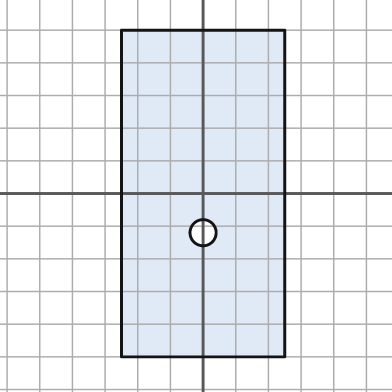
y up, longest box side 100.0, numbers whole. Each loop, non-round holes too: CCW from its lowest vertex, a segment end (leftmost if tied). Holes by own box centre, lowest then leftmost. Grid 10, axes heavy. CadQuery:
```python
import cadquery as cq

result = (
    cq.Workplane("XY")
    .moveTo(-25.0, -50.0)
    .lineTo(25.0, -50.0)
    .lineTo(25.0, 50.0)
    .lineTo(-25.0, 50.0)
    .close()
    .moveTo(0.0, -12.0)
    .circle(4.0)
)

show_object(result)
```